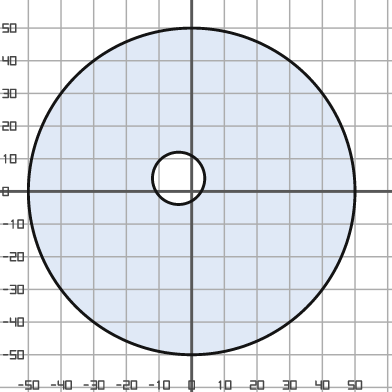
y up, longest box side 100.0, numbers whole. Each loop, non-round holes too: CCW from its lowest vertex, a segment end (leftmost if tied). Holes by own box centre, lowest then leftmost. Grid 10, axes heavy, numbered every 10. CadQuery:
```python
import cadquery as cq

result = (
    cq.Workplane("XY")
    .moveTo(0.0, 0.0)
    .circle(50.0)
    .moveTo(-4.0, 4.0)
    .circle(8.0)
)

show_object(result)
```